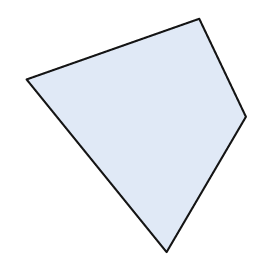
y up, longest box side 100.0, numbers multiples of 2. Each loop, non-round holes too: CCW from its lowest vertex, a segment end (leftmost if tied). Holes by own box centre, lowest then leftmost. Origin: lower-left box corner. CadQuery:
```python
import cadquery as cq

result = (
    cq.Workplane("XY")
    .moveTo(60.0, 0.0)
    .lineTo(94.0, 58.0)
    .lineTo(74.0, 100.0)
    .lineTo(0.0, 74.0)
    .close()
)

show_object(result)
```